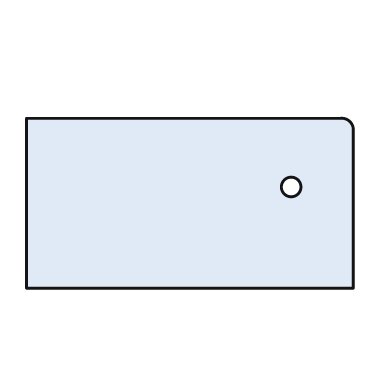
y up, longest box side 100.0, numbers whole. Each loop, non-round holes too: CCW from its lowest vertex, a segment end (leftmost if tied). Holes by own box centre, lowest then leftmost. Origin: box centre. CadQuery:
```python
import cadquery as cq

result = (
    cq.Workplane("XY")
    .moveTo(-50.0, -26.0)
    .lineTo(50.0, -26.0)
    .lineTo(50.0, 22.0)
    .threePointArc((49.0, 25.0), (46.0, 26.0))
    .lineTo(-50.0, 26.0)
    .close()
    .moveTo(31.0, 5.0)
    .circle(3.0)
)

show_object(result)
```